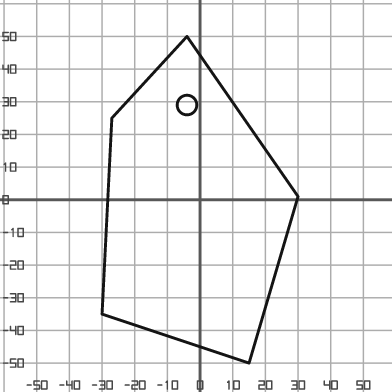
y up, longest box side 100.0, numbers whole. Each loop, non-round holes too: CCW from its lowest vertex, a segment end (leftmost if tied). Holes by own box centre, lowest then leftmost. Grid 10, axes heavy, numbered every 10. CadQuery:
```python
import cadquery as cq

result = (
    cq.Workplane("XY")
    .moveTo(15.0, -50.0)
    .lineTo(30.0, 1.0)
    .lineTo(-4.0, 50.0)
    .lineTo(-27.0, 25.0)
    .lineTo(-30.0, -35.0)
    .close()
    .moveTo(-4.0, 29.0)
    .circle(3.0)
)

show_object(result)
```